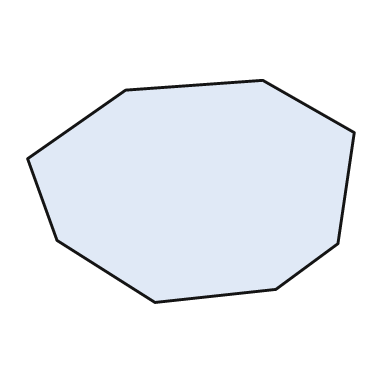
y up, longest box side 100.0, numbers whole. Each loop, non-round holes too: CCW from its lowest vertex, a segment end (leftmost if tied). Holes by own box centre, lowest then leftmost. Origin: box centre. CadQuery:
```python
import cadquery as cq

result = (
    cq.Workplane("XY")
    .moveTo(-11.0, -34.0)
    .lineTo(26.0, -30.0)
    .lineTo(45.0, -16.0)
    .lineTo(50.0, 18.0)
    .lineTo(22.0, 34.0)
    .lineTo(-20.0, 31.0)
    .lineTo(-50.0, 10.0)
    .lineTo(-41.0, -15.0)
    .close()
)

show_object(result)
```